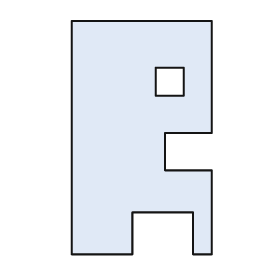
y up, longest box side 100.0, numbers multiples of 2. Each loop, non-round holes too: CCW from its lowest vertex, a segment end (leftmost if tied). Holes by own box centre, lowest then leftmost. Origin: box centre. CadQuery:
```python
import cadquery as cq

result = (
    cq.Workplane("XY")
    .moveTo(-30.0, -50.0)
    .lineTo(-4.0, -50.0)
    .lineTo(-4.0, -32.0)
    .lineTo(22.0, -32.0)
    .lineTo(22.0, -50.0)
    .lineTo(30.0, -50.0)
    .lineTo(30.0, -14.0)
    .lineTo(10.0, -14.0)
    .lineTo(10.0, 2.0)
    .lineTo(30.0, 2.0)
    .lineTo(30.0, 50.0)
    .lineTo(-30.0, 50.0)
    .close()
    .moveTo(6.0, 18.0)
    .lineTo(18.0, 18.0)
    .lineTo(18.0, 30.0)
    .lineTo(6.0, 30.0)
    .close()
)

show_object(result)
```